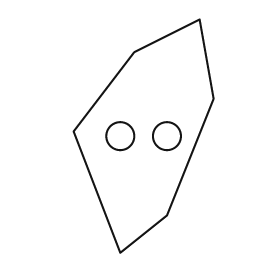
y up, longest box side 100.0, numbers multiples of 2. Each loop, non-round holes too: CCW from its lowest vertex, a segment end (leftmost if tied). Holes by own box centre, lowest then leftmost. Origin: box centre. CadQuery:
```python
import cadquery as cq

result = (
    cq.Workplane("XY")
    .moveTo(-10.0, -50.0)
    .lineTo(10.0, -34.0)
    .lineTo(30.0, 16.0)
    .lineTo(24.0, 50.0)
    .lineTo(-4.0, 36.0)
    .lineTo(-30.0, 2.0)
    .close()
    .moveTo(-10.0, 0.0)
    .circle(6.0)
    .moveTo(10.0, 0.0)
    .circle(6.0)
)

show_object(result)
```